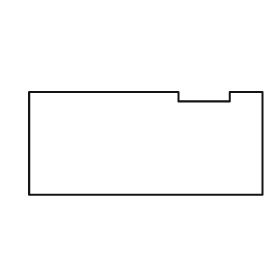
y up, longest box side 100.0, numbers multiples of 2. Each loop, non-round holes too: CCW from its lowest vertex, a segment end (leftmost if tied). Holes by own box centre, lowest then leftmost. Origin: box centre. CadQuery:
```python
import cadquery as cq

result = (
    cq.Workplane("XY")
    .moveTo(-50.0, -22.0)
    .lineTo(50.0, -22.0)
    .lineTo(50.0, 22.0)
    .lineTo(36.0, 22.0)
    .lineTo(36.0, 18.0)
    .lineTo(14.0, 18.0)
    .lineTo(14.0, 22.0)
    .lineTo(-50.0, 22.0)
    .close()
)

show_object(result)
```